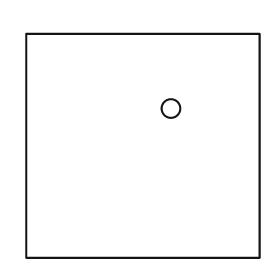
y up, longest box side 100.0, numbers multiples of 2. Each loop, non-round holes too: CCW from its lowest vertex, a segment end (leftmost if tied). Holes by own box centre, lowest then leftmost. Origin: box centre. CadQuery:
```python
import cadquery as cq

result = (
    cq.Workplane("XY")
    .moveTo(-50.0, -48.0)
    .lineTo(50.0, -48.0)
    .lineTo(50.0, 48.0)
    .lineTo(-50.0, 48.0)
    .close()
    .moveTo(12.0, 16.0)
    .circle(4.0)
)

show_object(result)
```